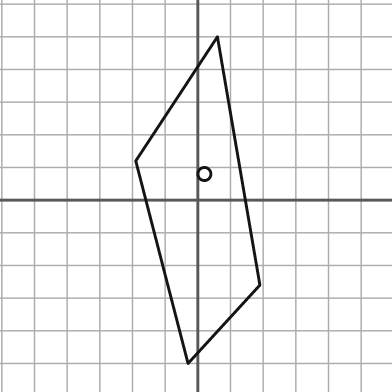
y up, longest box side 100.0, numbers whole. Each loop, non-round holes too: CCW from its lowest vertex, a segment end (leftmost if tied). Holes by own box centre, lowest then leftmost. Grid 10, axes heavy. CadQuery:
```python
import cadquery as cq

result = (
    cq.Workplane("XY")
    .moveTo(-3.0, -50.0)
    .lineTo(19.0, -26.0)
    .lineTo(6.0, 50.0)
    .lineTo(-19.0, 12.0)
    .close()
    .moveTo(2.0, 8.0)
    .circle(2.0)
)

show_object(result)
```